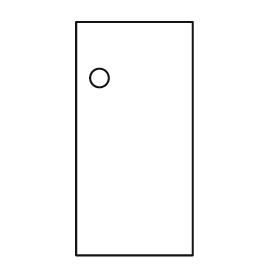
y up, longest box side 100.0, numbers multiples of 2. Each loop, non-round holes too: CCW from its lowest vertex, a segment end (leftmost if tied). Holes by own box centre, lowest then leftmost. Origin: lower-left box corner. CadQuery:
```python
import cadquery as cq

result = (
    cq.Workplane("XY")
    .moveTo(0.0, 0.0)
    .lineTo(50.0, 0.0)
    .lineTo(50.0, 100.0)
    .lineTo(0.0, 100.0)
    .close()
    .moveTo(10.0, 76.0)
    .circle(4.0)
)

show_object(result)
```